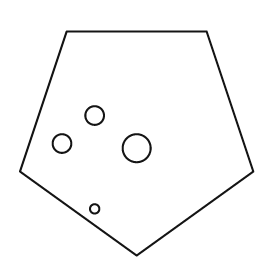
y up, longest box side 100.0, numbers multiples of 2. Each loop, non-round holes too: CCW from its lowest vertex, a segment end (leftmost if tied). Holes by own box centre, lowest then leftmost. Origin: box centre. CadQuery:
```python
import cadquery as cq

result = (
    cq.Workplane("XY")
    .moveTo(0.0, -48.0)
    .lineTo(50.0, -12.0)
    .lineTo(30.0, 48.0)
    .lineTo(-30.0, 48.0)
    .lineTo(-50.0, -12.0)
    .close()
    .moveTo(-18.0, -28.0)
    .circle(2.0)
    .moveTo(0.0, -2.0)
    .circle(6.0)
    .moveTo(-32.0, 0.0)
    .circle(4.0)
    .moveTo(-18.0, 12.0)
    .circle(4.0)
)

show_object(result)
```